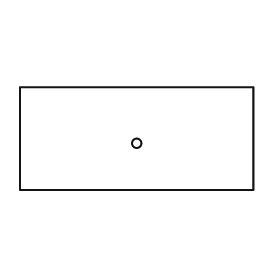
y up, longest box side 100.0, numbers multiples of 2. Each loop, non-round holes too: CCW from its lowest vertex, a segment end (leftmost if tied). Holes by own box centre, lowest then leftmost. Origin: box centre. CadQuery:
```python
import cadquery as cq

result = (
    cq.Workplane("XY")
    .moveTo(-50.0, -22.0)
    .lineTo(50.0, -22.0)
    .lineTo(50.0, 22.0)
    .lineTo(-50.0, 22.0)
    .close()
    .moveTo(0.0, -2.0)
    .circle(2.0)
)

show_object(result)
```